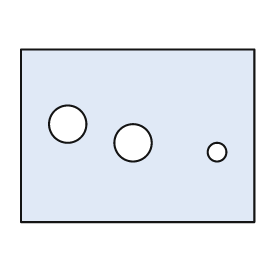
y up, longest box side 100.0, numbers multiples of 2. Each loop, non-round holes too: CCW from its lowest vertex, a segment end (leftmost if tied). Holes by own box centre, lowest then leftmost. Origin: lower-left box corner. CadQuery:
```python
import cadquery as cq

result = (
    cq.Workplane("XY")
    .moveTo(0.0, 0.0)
    .lineTo(100.0, 0.0)
    .lineTo(100.0, 74.0)
    .lineTo(0.0, 74.0)
    .close()
    .moveTo(84.0, 30.0)
    .circle(4.0)
    .moveTo(48.0, 34.0)
    .circle(8.0)
    .moveTo(20.0, 42.0)
    .circle(8.0)
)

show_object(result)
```